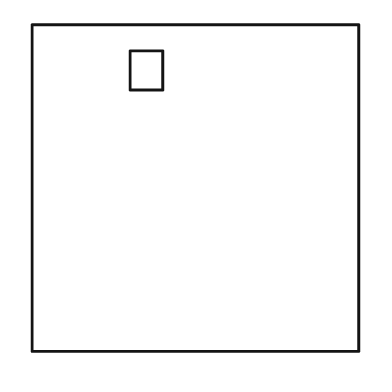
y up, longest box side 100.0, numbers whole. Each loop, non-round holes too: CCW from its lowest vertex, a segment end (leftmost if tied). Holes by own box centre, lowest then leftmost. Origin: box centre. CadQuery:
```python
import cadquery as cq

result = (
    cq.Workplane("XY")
    .moveTo(-50.0, -50.0)
    .lineTo(50.0, -50.0)
    .lineTo(50.0, 50.0)
    .lineTo(-50.0, 50.0)
    .close()
    .moveTo(-20.0, 30.0)
    .lineTo(-10.0, 30.0)
    .lineTo(-10.0, 42.0)
    .lineTo(-20.0, 42.0)
    .close()
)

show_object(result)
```